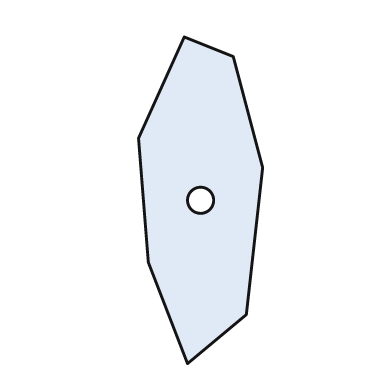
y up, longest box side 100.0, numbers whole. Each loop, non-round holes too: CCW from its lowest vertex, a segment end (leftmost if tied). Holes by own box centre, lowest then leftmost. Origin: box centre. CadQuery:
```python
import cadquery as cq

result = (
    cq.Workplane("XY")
    .moveTo(-4.0, -50.0)
    .lineTo(14.0, -35.0)
    .lineTo(19.0, 10.0)
    .lineTo(10.0, 44.0)
    .lineTo(-5.0, 50.0)
    .lineTo(-19.0, 19.0)
    .lineTo(-16.0, -19.0)
    .close()
    .moveTo(0.0, 0.0)
    .circle(4.0)
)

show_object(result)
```